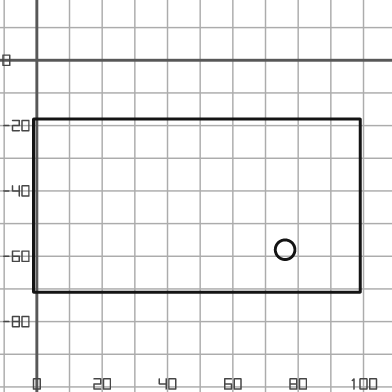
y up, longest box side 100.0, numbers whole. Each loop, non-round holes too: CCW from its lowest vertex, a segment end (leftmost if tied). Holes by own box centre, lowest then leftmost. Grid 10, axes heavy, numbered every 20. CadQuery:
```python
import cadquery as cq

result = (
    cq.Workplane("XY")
    .moveTo(-1.0, -71.0)
    .lineTo(99.0, -71.0)
    .lineTo(99.0, -18.0)
    .lineTo(-1.0, -18.0)
    .close()
    .moveTo(76.0, -58.0)
    .circle(3.0)
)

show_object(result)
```